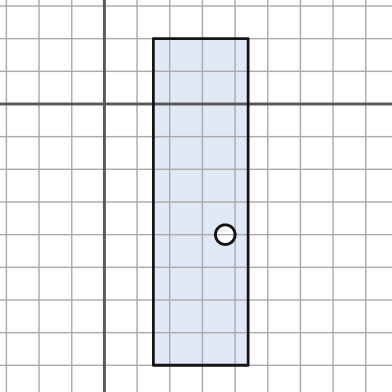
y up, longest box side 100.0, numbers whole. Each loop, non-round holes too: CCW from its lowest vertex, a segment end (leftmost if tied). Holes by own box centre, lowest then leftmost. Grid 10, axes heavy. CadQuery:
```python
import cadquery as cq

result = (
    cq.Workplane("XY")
    .moveTo(15.0, -80.0)
    .lineTo(44.0, -80.0)
    .lineTo(44.0, 20.0)
    .lineTo(15.0, 20.0)
    .close()
    .moveTo(37.0, -40.0)
    .circle(3.0)
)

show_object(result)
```